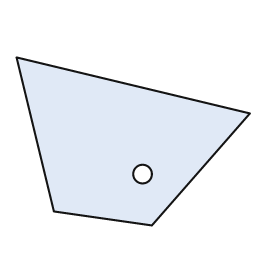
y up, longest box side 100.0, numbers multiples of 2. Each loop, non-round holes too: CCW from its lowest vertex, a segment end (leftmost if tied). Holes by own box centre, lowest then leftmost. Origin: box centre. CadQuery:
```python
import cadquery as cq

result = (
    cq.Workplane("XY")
    .moveTo(8.0, -36.0)
    .lineTo(50.0, 12.0)
    .lineTo(-50.0, 36.0)
    .lineTo(-34.0, -30.0)
    .close()
    .moveTo(4.0, -14.0)
    .circle(4.0)
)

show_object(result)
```